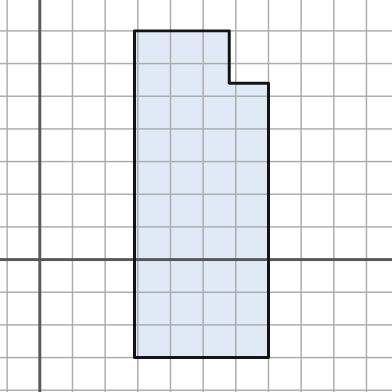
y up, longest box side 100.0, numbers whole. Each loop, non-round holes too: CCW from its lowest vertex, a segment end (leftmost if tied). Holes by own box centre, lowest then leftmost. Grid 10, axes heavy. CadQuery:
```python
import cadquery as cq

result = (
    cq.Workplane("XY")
    .moveTo(29.0, -30.0)
    .lineTo(70.0, -30.0)
    .lineTo(70.0, 54.0)
    .lineTo(58.0, 54.0)
    .lineTo(58.0, 70.0)
    .lineTo(29.0, 70.0)
    .close()
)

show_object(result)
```